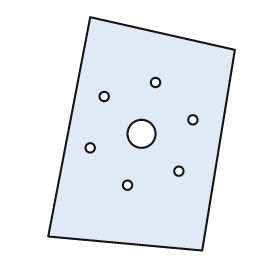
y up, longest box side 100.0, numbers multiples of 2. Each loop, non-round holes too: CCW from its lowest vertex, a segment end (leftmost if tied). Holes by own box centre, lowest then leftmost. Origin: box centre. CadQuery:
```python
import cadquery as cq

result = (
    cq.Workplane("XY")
    .moveTo(26.0, -50.0)
    .lineTo(40.0, 36.0)
    .lineTo(-22.0, 50.0)
    .lineTo(-40.0, -44.0)
    .close()
    .moveTo(-6.0, -22.0)
    .circle(2.0)
    .moveTo(16.0, -16.0)
    .circle(2.0)
    .moveTo(-22.0, -6.0)
    .circle(2.0)
    .moveTo(0.0, 0.0)
    .circle(6.0)
    .moveTo(22.0, 6.0)
    .circle(2.0)
    .moveTo(-16.0, 16.0)
    .circle(2.0)
    .moveTo(6.0, 22.0)
    .circle(2.0)
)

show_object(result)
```